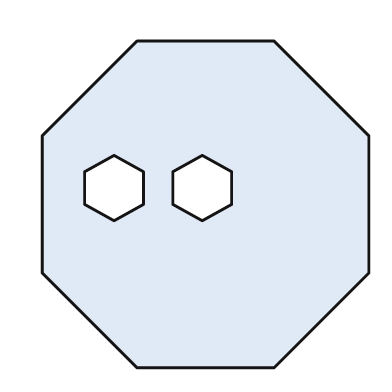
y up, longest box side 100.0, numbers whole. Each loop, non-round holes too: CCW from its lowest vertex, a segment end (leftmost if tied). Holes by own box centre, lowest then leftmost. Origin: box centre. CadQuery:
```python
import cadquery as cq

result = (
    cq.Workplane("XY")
    .moveTo(-21.0, -50.0)
    .lineTo(21.0, -50.0)
    .lineTo(50.0, -21.0)
    .lineTo(50.0, 21.0)
    .lineTo(21.0, 50.0)
    .lineTo(-21.0, 50.0)
    .lineTo(-50.0, 21.0)
    .lineTo(-50.0, -21.0)
    .close()
    .moveTo(-28.0, -5.0)
    .lineTo(-19.0, 0.0)
    .lineTo(-19.0, 10.0)
    .lineTo(-28.0, 15.0)
    .lineTo(-37.0, 10.0)
    .lineTo(-37.0, 0.0)
    .close()
    .moveTo(-1.0, -5.0)
    .lineTo(8.0, 0.0)
    .lineTo(8.0, 10.0)
    .lineTo(-1.0, 15.0)
    .lineTo(-10.0, 10.0)
    .lineTo(-10.0, 0.0)
    .close()
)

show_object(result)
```